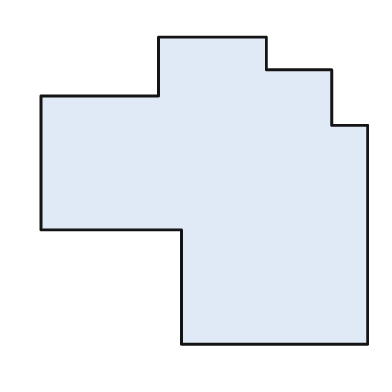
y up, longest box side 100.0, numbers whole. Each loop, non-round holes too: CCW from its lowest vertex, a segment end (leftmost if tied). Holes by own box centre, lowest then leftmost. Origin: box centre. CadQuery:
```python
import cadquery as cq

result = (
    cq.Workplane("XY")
    .moveTo(-7.0, -47.0)
    .lineTo(50.0, -47.0)
    .lineTo(50.0, 20.0)
    .lineTo(39.0, 20.0)
    .lineTo(39.0, 37.0)
    .lineTo(19.0, 37.0)
    .lineTo(19.0, 47.0)
    .lineTo(-14.0, 47.0)
    .lineTo(-14.0, 29.0)
    .lineTo(-50.0, 29.0)
    .lineTo(-50.0, -12.0)
    .lineTo(-7.0, -12.0)
    .close()
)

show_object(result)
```